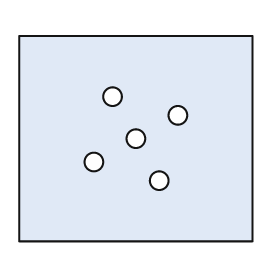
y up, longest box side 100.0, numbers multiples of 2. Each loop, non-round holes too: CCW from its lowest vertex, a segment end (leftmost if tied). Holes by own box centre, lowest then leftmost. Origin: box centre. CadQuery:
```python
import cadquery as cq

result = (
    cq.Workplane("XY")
    .moveTo(-50.0, -44.0)
    .lineTo(50.0, -44.0)
    .lineTo(50.0, 44.0)
    .lineTo(-50.0, 44.0)
    .close()
    .moveTo(10.0, -18.0)
    .circle(4.0)
    .moveTo(-18.0, -10.0)
    .circle(4.0)
    .moveTo(0.0, 0.0)
    .circle(4.0)
    .moveTo(18.0, 10.0)
    .circle(4.0)
    .moveTo(-10.0, 18.0)
    .circle(4.0)
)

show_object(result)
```